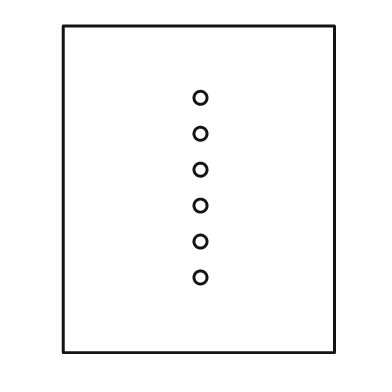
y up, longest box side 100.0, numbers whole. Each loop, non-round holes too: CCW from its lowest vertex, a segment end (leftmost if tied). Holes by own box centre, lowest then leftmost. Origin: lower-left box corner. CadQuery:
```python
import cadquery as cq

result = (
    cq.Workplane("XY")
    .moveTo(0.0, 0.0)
    .lineTo(83.0, 0.0)
    .lineTo(83.0, 100.0)
    .lineTo(0.0, 100.0)
    .close()
    .moveTo(42.0, 23.0)
    .circle(2.0)
    .moveTo(42.0, 34.0)
    .circle(2.0)
    .moveTo(42.0, 45.0)
    .circle(2.0)
    .moveTo(42.0, 56.0)
    .circle(2.0)
    .moveTo(42.0, 67.0)
    .circle(2.0)
    .moveTo(42.0, 78.0)
    .circle(2.0)
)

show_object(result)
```